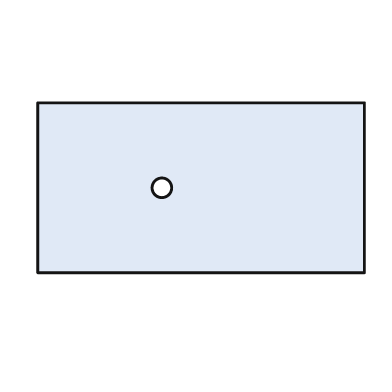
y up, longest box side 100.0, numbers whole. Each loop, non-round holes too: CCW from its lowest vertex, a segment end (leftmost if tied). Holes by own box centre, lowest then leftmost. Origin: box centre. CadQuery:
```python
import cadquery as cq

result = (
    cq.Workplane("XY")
    .moveTo(-50.0, -26.0)
    .lineTo(50.0, -26.0)
    .lineTo(50.0, 26.0)
    .lineTo(-50.0, 26.0)
    .close()
    .moveTo(-12.0, 0.0)
    .circle(3.0)
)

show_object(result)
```